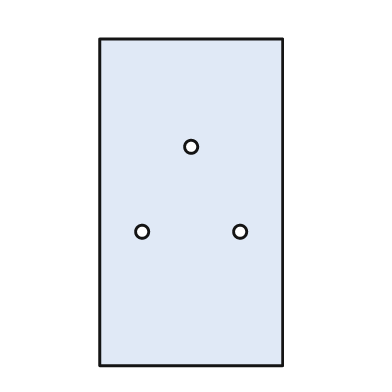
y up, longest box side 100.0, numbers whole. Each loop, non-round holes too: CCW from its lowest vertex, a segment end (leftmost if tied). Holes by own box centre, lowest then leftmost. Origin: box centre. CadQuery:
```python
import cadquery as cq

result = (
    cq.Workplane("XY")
    .moveTo(-28.0, -50.0)
    .lineTo(28.0, -50.0)
    .lineTo(28.0, 50.0)
    .lineTo(-28.0, 50.0)
    .close()
    .moveTo(-15.0, -9.0)
    .circle(2.0)
    .moveTo(15.0, -9.0)
    .circle(2.0)
    .moveTo(0.0, 17.0)
    .circle(2.0)
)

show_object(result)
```